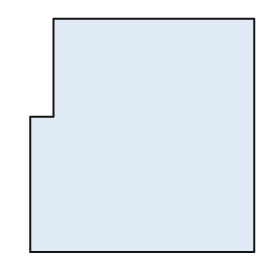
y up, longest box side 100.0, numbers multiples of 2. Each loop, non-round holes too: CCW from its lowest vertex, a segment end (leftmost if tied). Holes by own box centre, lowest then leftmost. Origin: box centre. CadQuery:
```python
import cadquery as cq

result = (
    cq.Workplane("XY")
    .moveTo(-48.0, -50.0)
    .lineTo(48.0, -50.0)
    .lineTo(48.0, 50.0)
    .lineTo(-38.0, 50.0)
    .lineTo(-38.0, 8.0)
    .lineTo(-48.0, 8.0)
    .close()
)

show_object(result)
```